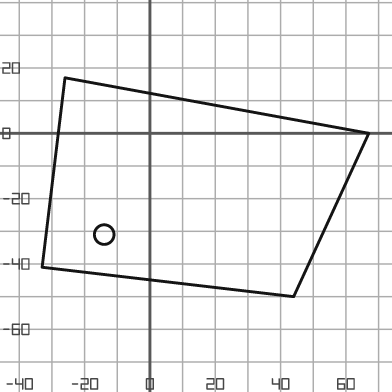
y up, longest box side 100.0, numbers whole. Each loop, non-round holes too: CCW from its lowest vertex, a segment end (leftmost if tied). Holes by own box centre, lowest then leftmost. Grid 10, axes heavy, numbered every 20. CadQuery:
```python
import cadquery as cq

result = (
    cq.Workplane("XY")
    .moveTo(44.0, -50.0)
    .lineTo(67.0, 0.0)
    .lineTo(-26.0, 17.0)
    .lineTo(-33.0, -41.0)
    .close()
    .moveTo(-14.0, -31.0)
    .circle(3.0)
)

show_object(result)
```